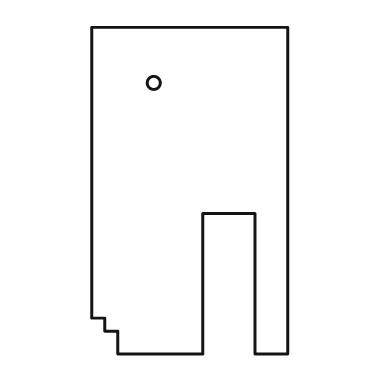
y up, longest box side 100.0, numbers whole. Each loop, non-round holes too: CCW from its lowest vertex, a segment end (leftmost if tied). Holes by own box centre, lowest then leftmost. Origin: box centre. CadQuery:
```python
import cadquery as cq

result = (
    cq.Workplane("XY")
    .moveTo(-22.0, -50.0)
    .lineTo(4.0, -50.0)
    .lineTo(4.0, -7.0)
    .lineTo(20.0, -7.0)
    .lineTo(20.0, -50.0)
    .lineTo(30.0, -50.0)
    .lineTo(30.0, 50.0)
    .lineTo(-30.0, 50.0)
    .lineTo(-30.0, -39.0)
    .lineTo(-26.0, -39.0)
    .lineTo(-26.0, -43.0)
    .lineTo(-22.0, -43.0)
    .close()
    .moveTo(-11.0, 33.0)
    .circle(2.0)
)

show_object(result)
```